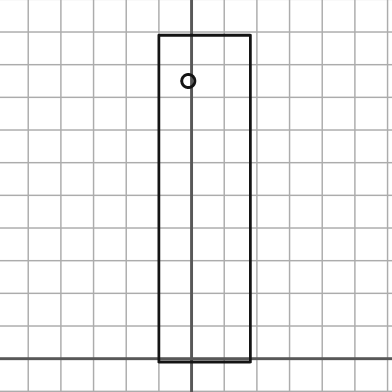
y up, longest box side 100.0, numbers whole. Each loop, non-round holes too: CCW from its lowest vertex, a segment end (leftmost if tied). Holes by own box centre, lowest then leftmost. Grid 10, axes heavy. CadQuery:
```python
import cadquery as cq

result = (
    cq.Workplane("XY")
    .moveTo(-10.0, -1.0)
    .lineTo(18.0, -1.0)
    .lineTo(18.0, 99.0)
    .lineTo(-10.0, 99.0)
    .close()
    .moveTo(-1.0, 85.0)
    .circle(2.0)
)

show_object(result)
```